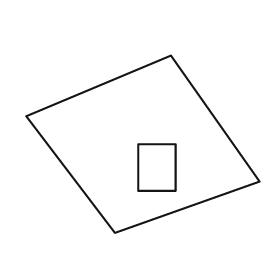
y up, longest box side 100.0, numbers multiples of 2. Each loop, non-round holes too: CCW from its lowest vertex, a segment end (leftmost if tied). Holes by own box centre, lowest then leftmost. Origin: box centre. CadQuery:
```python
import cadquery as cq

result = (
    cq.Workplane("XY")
    .moveTo(-12.0, -38.0)
    .lineTo(50.0, -16.0)
    .lineTo(12.0, 38.0)
    .lineTo(-50.0, 12.0)
    .close()
    .moveTo(-2.0, -20.0)
    .lineTo(14.0, -20.0)
    .lineTo(14.0, 0.0)
    .lineTo(-2.0, 0.0)
    .close()
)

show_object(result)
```